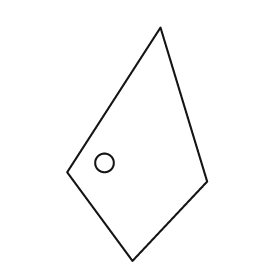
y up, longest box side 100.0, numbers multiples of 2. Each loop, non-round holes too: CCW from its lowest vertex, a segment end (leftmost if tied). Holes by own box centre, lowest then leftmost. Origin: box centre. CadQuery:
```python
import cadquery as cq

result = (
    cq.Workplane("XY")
    .moveTo(-2.0, -50.0)
    .lineTo(30.0, -16.0)
    .lineTo(10.0, 50.0)
    .lineTo(-30.0, -12.0)
    .close()
    .moveTo(-14.0, -8.0)
    .circle(4.0)
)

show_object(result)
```